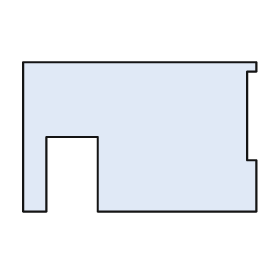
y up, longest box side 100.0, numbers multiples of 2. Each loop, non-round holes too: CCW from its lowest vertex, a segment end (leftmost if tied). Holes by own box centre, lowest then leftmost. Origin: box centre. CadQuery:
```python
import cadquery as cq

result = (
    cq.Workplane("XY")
    .moveTo(-50.0, -32.0)
    .lineTo(-40.0, -32.0)
    .lineTo(-40.0, 0.0)
    .lineTo(-18.0, 0.0)
    .lineTo(-18.0, -32.0)
    .lineTo(50.0, -32.0)
    .lineTo(50.0, -10.0)
    .lineTo(46.0, -10.0)
    .lineTo(46.0, 28.0)
    .lineTo(50.0, 28.0)
    .lineTo(50.0, 32.0)
    .lineTo(-50.0, 32.0)
    .close()
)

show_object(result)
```